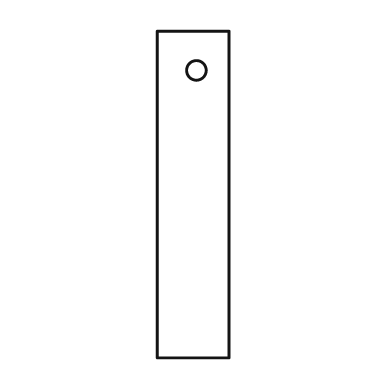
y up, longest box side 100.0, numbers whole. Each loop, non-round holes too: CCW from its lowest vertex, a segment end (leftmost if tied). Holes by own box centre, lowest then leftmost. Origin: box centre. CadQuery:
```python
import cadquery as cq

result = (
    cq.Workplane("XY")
    .moveTo(-11.0, -50.0)
    .lineTo(11.0, -50.0)
    .lineTo(11.0, 50.0)
    .lineTo(-11.0, 50.0)
    .close()
    .moveTo(1.0, 38.0)
    .circle(3.0)
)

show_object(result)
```